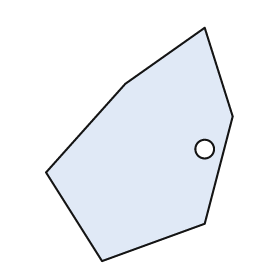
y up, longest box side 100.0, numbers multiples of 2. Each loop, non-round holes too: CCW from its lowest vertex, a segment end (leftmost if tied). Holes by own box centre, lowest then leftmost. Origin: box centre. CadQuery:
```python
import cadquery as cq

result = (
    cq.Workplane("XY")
    .moveTo(-16.0, -50.0)
    .lineTo(28.0, -34.0)
    .lineTo(40.0, 12.0)
    .lineTo(28.0, 50.0)
    .lineTo(-6.0, 26.0)
    .lineTo(-40.0, -12.0)
    .close()
    .moveTo(28.0, -2.0)
    .circle(4.0)
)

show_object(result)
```